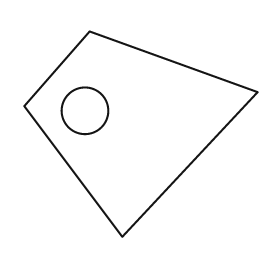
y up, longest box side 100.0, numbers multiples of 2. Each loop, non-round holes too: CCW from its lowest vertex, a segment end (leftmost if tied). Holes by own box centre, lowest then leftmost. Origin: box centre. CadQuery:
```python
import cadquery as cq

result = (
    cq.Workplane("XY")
    .moveTo(-8.0, -44.0)
    .lineTo(50.0, 18.0)
    .lineTo(-22.0, 44.0)
    .lineTo(-50.0, 12.0)
    .close()
    .moveTo(-24.0, 10.0)
    .circle(10.0)
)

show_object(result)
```